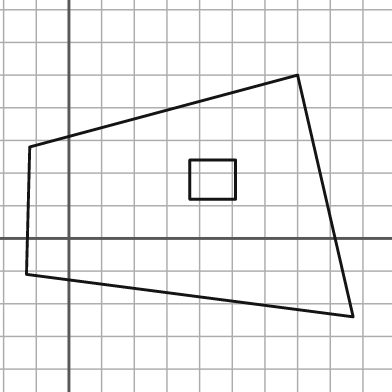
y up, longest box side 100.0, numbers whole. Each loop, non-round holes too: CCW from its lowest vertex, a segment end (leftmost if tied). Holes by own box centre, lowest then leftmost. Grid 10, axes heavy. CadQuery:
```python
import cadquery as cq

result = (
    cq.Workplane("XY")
    .moveTo(87.0, -24.0)
    .lineTo(70.0, 50.0)
    .lineTo(-12.0, 28.0)
    .lineTo(-13.0, -11.0)
    .close()
    .moveTo(37.0, 12.0)
    .lineTo(51.0, 12.0)
    .lineTo(51.0, 24.0)
    .lineTo(37.0, 24.0)
    .close()
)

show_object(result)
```